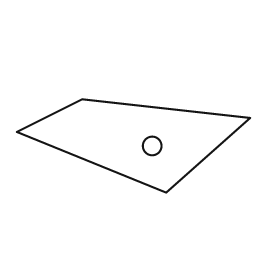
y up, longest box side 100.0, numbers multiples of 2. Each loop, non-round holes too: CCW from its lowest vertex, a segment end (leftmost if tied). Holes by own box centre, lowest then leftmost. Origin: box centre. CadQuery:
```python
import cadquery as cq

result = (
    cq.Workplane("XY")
    .moveTo(14.0, -20.0)
    .lineTo(50.0, 12.0)
    .lineTo(-22.0, 20.0)
    .lineTo(-50.0, 6.0)
    .close()
    .moveTo(8.0, 0.0)
    .circle(4.0)
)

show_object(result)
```